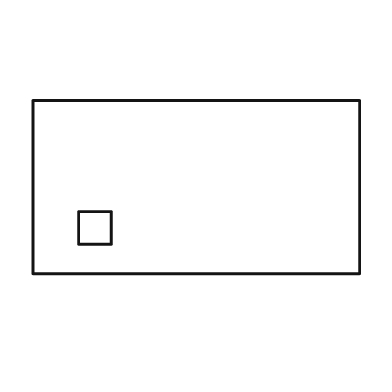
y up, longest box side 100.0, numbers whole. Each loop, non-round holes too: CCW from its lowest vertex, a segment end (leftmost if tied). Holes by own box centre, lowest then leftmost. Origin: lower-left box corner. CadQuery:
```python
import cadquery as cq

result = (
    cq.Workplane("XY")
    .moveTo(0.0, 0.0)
    .lineTo(100.0, 0.0)
    .lineTo(100.0, 53.0)
    .lineTo(0.0, 53.0)
    .close()
    .moveTo(14.0, 9.0)
    .lineTo(24.0, 9.0)
    .lineTo(24.0, 19.0)
    .lineTo(14.0, 19.0)
    .close()
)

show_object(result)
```